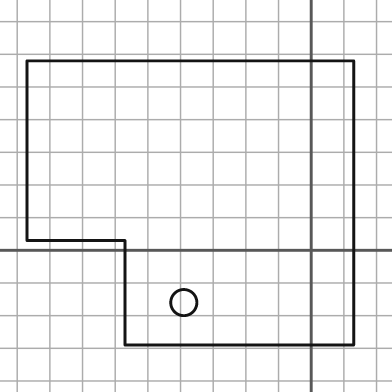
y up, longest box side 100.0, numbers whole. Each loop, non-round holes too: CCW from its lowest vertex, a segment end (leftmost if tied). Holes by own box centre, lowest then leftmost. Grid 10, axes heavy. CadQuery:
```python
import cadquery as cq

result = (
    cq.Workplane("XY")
    .moveTo(-57.0, -29.0)
    .lineTo(13.0, -29.0)
    .lineTo(13.0, 58.0)
    .lineTo(-87.0, 58.0)
    .lineTo(-87.0, 3.0)
    .lineTo(-57.0, 3.0)
    .close()
    .moveTo(-39.0, -16.0)
    .circle(4.0)
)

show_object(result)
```